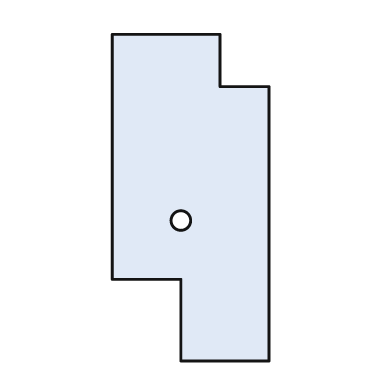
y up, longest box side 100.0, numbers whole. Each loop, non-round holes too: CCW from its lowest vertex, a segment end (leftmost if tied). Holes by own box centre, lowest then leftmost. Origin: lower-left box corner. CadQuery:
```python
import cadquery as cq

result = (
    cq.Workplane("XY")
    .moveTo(21.0, 0.0)
    .lineTo(48.0, 0.0)
    .lineTo(48.0, 84.0)
    .lineTo(33.0, 84.0)
    .lineTo(33.0, 100.0)
    .lineTo(0.0, 100.0)
    .lineTo(0.0, 25.0)
    .lineTo(21.0, 25.0)
    .close()
    .moveTo(21.0, 43.0)
    .circle(3.0)
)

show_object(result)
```